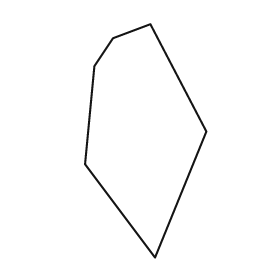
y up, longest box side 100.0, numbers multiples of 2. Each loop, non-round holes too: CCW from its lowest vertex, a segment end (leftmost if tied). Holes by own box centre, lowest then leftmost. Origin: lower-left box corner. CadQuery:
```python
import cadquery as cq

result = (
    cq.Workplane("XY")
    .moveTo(30.0, 0.0)
    .lineTo(52.0, 54.0)
    .lineTo(28.0, 100.0)
    .lineTo(12.0, 94.0)
    .lineTo(4.0, 82.0)
    .lineTo(0.0, 40.0)
    .close()
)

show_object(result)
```